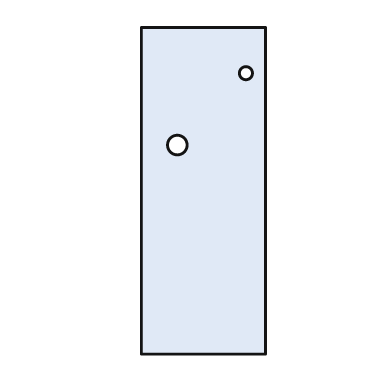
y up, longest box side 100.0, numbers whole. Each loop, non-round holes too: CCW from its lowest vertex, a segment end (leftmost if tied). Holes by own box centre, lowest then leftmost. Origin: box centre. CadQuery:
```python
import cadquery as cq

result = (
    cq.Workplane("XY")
    .moveTo(-19.0, -50.0)
    .lineTo(19.0, -50.0)
    .lineTo(19.0, 50.0)
    .lineTo(-19.0, 50.0)
    .close()
    .moveTo(-8.0, 14.0)
    .circle(3.0)
    .moveTo(13.0, 36.0)
    .circle(2.0)
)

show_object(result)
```